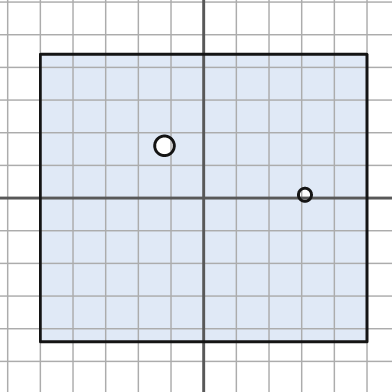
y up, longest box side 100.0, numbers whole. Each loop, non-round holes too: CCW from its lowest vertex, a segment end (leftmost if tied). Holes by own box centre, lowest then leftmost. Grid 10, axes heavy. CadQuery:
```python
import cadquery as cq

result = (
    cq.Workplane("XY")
    .moveTo(-50.0, -44.0)
    .lineTo(50.0, -44.0)
    .lineTo(50.0, 44.0)
    .lineTo(-50.0, 44.0)
    .close()
    .moveTo(31.0, 1.0)
    .circle(2.0)
    .moveTo(-12.0, 16.0)
    .circle(3.0)
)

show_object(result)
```